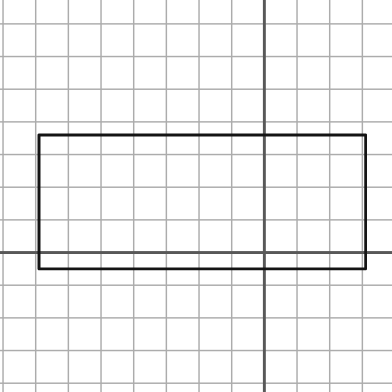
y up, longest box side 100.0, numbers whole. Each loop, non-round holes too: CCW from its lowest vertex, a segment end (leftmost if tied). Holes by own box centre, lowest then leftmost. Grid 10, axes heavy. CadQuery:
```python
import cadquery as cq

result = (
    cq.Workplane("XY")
    .moveTo(-69.0, -5.0)
    .lineTo(31.0, -5.0)
    .lineTo(31.0, 36.0)
    .lineTo(-69.0, 36.0)
    .close()
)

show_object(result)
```